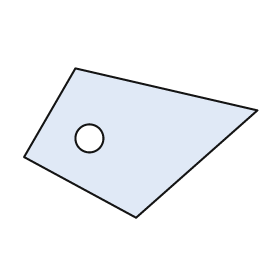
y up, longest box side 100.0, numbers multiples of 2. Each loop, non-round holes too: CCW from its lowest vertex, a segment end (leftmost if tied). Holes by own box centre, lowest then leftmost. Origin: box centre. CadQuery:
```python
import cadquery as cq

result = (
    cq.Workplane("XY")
    .moveTo(-2.0, -32.0)
    .lineTo(50.0, 14.0)
    .lineTo(-28.0, 32.0)
    .lineTo(-50.0, -6.0)
    .close()
    .moveTo(-22.0, 2.0)
    .circle(6.0)
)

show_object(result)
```